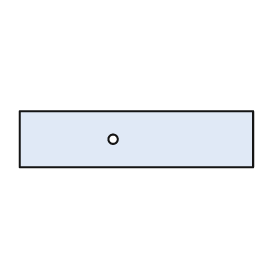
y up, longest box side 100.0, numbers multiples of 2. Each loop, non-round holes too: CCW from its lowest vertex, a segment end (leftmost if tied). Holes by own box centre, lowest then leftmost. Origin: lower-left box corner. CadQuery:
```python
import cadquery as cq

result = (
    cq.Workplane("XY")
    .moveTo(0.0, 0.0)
    .lineTo(100.0, 0.0)
    .lineTo(100.0, 24.0)
    .lineTo(0.0, 24.0)
    .close()
    .moveTo(40.0, 12.0)
    .circle(2.0)
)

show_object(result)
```